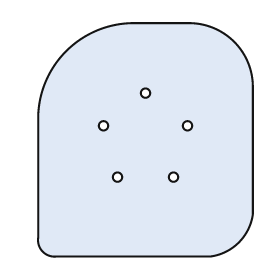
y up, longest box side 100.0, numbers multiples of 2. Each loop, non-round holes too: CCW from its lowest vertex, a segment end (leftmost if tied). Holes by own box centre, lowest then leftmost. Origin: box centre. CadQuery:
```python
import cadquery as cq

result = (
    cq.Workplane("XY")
    .moveTo(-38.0, -50.0)
    .lineTo(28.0, -50.0)
    .threePointArc((40.0, -44.0), (46.0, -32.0))
    .lineTo(46.0, 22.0)
    .threePointArc((38.0, 42.0), (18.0, 50.0))
    .lineTo(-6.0, 50.0)
    .threePointArc((-34.0, 38.0), (-46.0, 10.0))
    .lineTo(-46.0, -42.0)
    .threePointArc((-44.0, -48.0), (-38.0, -50.0))
    .close()
    .moveTo(-12.0, -16.0)
    .circle(2.0)
    .moveTo(12.0, -16.0)
    .circle(2.0)
    .moveTo(-18.0, 6.0)
    .circle(2.0)
    .moveTo(18.0, 6.0)
    .circle(2.0)
    .moveTo(0.0, 20.0)
    .circle(2.0)
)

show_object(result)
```